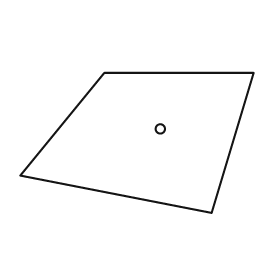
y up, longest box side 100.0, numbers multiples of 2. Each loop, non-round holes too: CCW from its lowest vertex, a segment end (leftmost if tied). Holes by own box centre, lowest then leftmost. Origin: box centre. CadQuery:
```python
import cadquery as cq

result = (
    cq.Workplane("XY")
    .moveTo(32.0, -30.0)
    .lineTo(50.0, 30.0)
    .lineTo(-14.0, 30.0)
    .lineTo(-50.0, -14.0)
    .close()
    .moveTo(10.0, 6.0)
    .circle(2.0)
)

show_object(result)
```